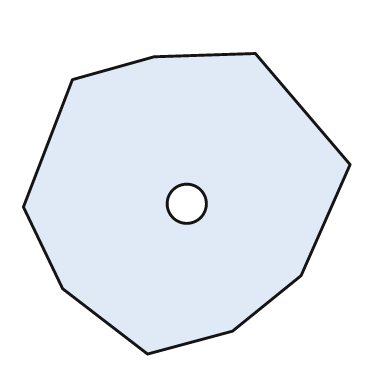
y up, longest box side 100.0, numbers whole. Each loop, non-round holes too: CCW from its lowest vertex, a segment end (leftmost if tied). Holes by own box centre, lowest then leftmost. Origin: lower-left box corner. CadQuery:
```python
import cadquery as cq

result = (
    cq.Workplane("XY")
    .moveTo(38.0, 0.0)
    .lineTo(64.0, 7.0)
    .lineTo(85.0, 24.0)
    .lineTo(100.0, 58.0)
    .lineTo(71.0, 92.0)
    .lineTo(40.0, 91.0)
    .lineTo(15.0, 84.0)
    .lineTo(0.0, 45.0)
    .lineTo(12.0, 20.0)
    .close()
    .moveTo(50.0, 46.0)
    .circle(6.0)
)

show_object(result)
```